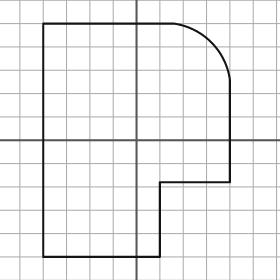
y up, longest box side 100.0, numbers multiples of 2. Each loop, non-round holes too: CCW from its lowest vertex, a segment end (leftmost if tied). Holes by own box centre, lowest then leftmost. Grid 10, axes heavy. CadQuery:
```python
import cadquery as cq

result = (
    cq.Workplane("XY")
    .moveTo(-40.0, -50.0)
    .lineTo(10.0, -50.0)
    .lineTo(10.0, -18.0)
    .lineTo(40.0, -18.0)
    .lineTo(40.0, 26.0)
    .threePointArc((32.0, 42.0), (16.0, 50.0))
    .lineTo(-40.0, 50.0)
    .close()
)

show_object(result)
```